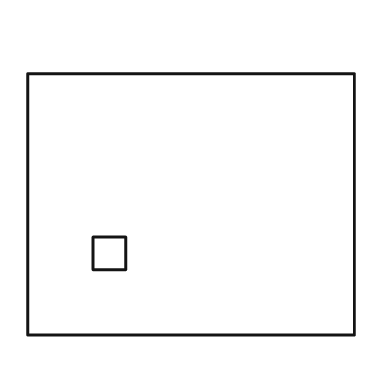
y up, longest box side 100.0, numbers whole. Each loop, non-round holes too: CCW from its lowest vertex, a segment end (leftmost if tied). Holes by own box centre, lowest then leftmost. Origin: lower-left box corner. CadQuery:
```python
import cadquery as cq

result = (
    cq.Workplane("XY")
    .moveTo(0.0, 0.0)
    .lineTo(100.0, 0.0)
    .lineTo(100.0, 80.0)
    .lineTo(0.0, 80.0)
    .close()
    .moveTo(20.0, 20.0)
    .lineTo(30.0, 20.0)
    .lineTo(30.0, 30.0)
    .lineTo(20.0, 30.0)
    .close()
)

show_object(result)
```